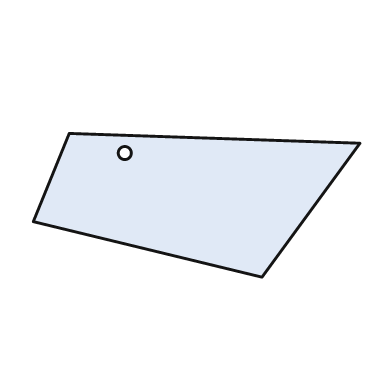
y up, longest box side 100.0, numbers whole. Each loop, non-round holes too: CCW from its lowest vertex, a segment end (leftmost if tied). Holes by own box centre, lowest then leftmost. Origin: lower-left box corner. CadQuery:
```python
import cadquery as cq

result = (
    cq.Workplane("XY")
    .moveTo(70.0, 0.0)
    .lineTo(100.0, 41.0)
    .lineTo(11.0, 44.0)
    .lineTo(0.0, 17.0)
    .close()
    .moveTo(28.0, 38.0)
    .circle(2.0)
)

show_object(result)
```